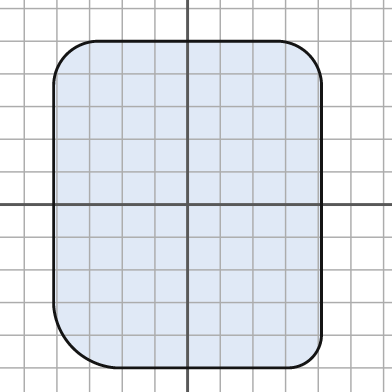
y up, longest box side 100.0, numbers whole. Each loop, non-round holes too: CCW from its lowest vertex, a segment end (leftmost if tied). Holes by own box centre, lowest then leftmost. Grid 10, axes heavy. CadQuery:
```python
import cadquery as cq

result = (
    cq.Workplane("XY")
    .moveTo(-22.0, -50.0)
    .lineTo(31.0, -50.0)
    .threePointArc((38.0, -47.0), (41.0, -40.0))
    .lineTo(41.0, 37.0)
    .threePointArc((37.0, 46.0), (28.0, 50.0))
    .lineTo(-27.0, 50.0)
    .threePointArc((-37.0, 46.0), (-41.0, 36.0))
    .lineTo(-41.0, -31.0)
    .threePointArc((-35.0, -44.0), (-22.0, -50.0))
    .close()
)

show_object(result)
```